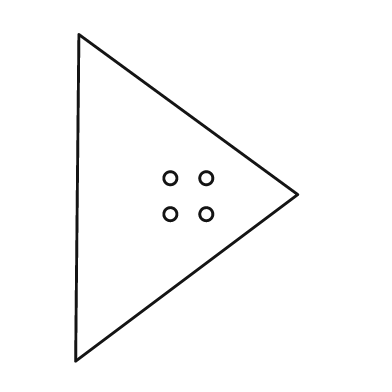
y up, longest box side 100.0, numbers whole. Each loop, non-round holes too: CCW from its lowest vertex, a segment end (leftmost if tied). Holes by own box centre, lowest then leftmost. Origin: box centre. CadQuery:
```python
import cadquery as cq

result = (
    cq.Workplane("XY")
    .moveTo(-34.0, -50.0)
    .lineTo(34.0, 1.0)
    .lineTo(-33.0, 50.0)
    .close()
    .moveTo(-5.0, -5.0)
    .circle(2.0)
    .moveTo(6.0, -5.0)
    .circle(2.0)
    .moveTo(-5.0, 6.0)
    .circle(2.0)
    .moveTo(6.0, 6.0)
    .circle(2.0)
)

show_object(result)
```